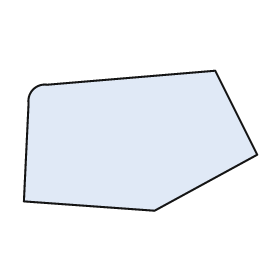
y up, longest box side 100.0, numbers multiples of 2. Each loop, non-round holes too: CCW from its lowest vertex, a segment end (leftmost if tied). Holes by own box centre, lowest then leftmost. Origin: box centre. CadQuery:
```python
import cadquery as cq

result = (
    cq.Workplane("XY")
    .moveTo(6.0, -30.0)
    .lineTo(50.0, -6.0)
    .lineTo(32.0, 30.0)
    .lineTo(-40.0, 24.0)
    .threePointArc((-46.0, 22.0), (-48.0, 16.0))
    .lineTo(-50.0, -26.0)
    .close()
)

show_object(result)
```